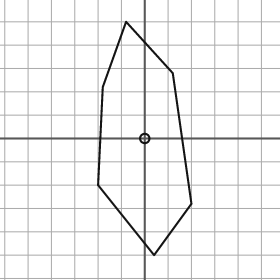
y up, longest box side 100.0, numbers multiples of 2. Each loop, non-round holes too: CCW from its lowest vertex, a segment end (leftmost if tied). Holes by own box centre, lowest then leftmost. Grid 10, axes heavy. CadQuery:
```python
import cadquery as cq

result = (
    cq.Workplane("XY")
    .moveTo(4.0, -50.0)
    .lineTo(20.0, -28.0)
    .lineTo(12.0, 28.0)
    .lineTo(-8.0, 50.0)
    .lineTo(-18.0, 22.0)
    .lineTo(-20.0, -20.0)
    .close()
    .moveTo(0.0, 0.0)
    .circle(2.0)
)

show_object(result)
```